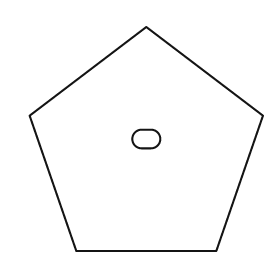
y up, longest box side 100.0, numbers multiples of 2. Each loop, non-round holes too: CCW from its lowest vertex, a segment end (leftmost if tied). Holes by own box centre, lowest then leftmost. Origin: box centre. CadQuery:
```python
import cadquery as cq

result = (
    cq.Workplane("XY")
    .moveTo(-30.0, -48.0)
    .lineTo(30.0, -48.0)
    .lineTo(50.0, 10.0)
    .lineTo(0.0, 48.0)
    .lineTo(-50.0, 10.0)
    .close()
    .moveTo(-2.0, -4.0)
    .lineTo(2.0, -4.0)
    .threePointArc((6.0, 0.0), (2.0, 4.0))
    .lineTo(-2.0, 4.0)
    .threePointArc((-6.0, 0.0), (-2.0, -4.0))
    .close()
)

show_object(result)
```